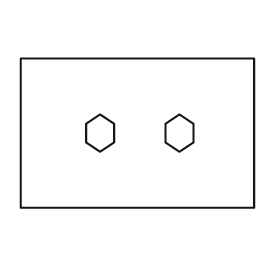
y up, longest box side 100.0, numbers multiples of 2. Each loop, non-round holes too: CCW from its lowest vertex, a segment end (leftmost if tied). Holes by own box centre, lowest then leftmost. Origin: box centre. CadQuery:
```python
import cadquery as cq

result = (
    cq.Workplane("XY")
    .moveTo(-50.0, -32.0)
    .lineTo(50.0, -32.0)
    .lineTo(50.0, 32.0)
    .lineTo(-50.0, 32.0)
    .close()
    .moveTo(-16.0, -8.0)
    .lineTo(-10.0, -4.0)
    .lineTo(-10.0, 4.0)
    .lineTo(-16.0, 8.0)
    .lineTo(-22.0, 4.0)
    .lineTo(-22.0, -4.0)
    .close()
    .moveTo(18.0, -8.0)
    .lineTo(24.0, -4.0)
    .lineTo(24.0, 4.0)
    .lineTo(18.0, 8.0)
    .lineTo(12.0, 4.0)
    .lineTo(12.0, -4.0)
    .close()
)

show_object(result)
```